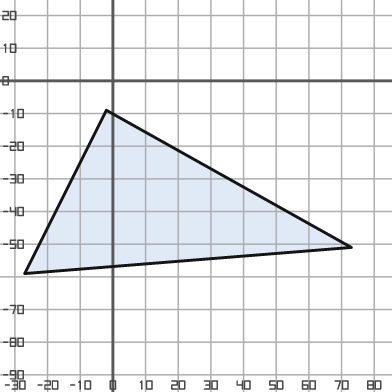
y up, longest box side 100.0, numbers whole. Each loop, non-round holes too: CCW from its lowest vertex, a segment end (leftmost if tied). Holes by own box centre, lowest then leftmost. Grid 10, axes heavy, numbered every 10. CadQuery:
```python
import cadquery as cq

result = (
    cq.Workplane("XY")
    .moveTo(-27.0, -59.0)
    .lineTo(73.0, -51.0)
    .lineTo(-2.0, -9.0)
    .close()
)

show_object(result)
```